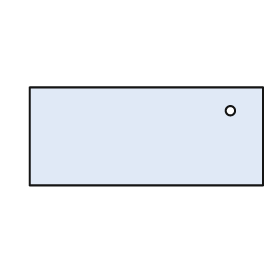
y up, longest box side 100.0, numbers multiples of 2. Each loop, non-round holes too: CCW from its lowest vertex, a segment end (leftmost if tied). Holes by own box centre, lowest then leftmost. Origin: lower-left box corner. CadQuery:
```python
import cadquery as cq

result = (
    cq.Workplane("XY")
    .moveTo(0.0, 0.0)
    .lineTo(100.0, 0.0)
    .lineTo(100.0, 42.0)
    .lineTo(0.0, 42.0)
    .close()
    .moveTo(86.0, 32.0)
    .circle(2.0)
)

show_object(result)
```